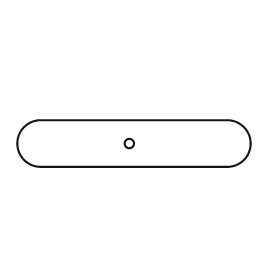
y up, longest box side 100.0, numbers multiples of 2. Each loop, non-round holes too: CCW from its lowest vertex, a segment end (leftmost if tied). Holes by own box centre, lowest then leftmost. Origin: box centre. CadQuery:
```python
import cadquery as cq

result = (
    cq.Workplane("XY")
    .moveTo(-40.0, -10.0)
    .lineTo(40.0, -10.0)
    .threePointArc((50.0, 0.0), (40.0, 10.0))
    .lineTo(-40.0, 10.0)
    .threePointArc((-50.0, 0.0), (-40.0, -10.0))
    .close()
    .moveTo(-2.0, 0.0)
    .circle(2.0)
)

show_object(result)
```